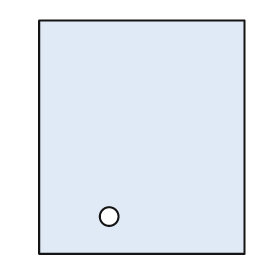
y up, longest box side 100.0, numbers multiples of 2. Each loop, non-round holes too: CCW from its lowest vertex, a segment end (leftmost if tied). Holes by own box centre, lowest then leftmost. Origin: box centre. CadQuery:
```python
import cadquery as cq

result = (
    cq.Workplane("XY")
    .moveTo(-44.0, -50.0)
    .lineTo(44.0, -50.0)
    .lineTo(44.0, 50.0)
    .lineTo(-44.0, 50.0)
    .close()
    .moveTo(-14.0, -34.0)
    .circle(4.0)
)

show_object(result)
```